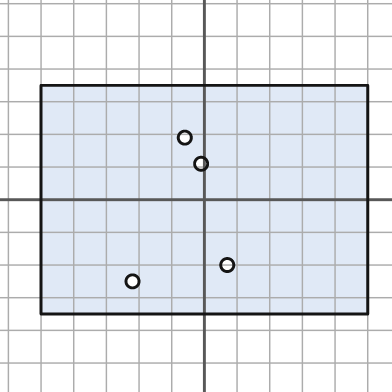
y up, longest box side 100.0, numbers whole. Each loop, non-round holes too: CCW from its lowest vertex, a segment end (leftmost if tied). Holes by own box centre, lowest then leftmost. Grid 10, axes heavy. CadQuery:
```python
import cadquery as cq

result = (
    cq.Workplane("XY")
    .moveTo(-50.0, -35.0)
    .lineTo(50.0, -35.0)
    .lineTo(50.0, 35.0)
    .lineTo(-50.0, 35.0)
    .close()
    .moveTo(-22.0, -25.0)
    .circle(2.0)
    .moveTo(7.0, -20.0)
    .circle(2.0)
    .moveTo(-1.0, 11.0)
    .circle(2.0)
    .moveTo(-6.0, 19.0)
    .circle(2.0)
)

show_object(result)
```